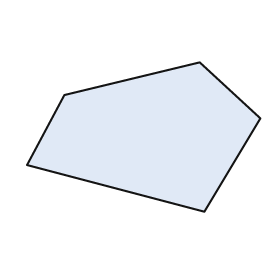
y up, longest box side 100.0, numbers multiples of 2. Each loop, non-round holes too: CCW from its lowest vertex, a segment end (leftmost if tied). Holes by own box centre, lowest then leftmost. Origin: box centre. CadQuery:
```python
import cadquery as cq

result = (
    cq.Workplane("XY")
    .moveTo(26.0, -32.0)
    .lineTo(50.0, 8.0)
    .lineTo(24.0, 32.0)
    .lineTo(-34.0, 18.0)
    .lineTo(-50.0, -12.0)
    .close()
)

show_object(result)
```